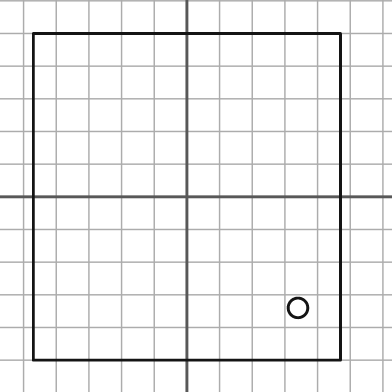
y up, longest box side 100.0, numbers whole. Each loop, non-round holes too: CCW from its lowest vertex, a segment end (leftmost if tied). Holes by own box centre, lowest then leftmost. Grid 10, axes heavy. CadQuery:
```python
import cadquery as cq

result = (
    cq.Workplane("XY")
    .moveTo(-47.0, -50.0)
    .lineTo(47.0, -50.0)
    .lineTo(47.0, 50.0)
    .lineTo(-47.0, 50.0)
    .close()
    .moveTo(34.0, -34.0)
    .circle(3.0)
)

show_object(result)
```